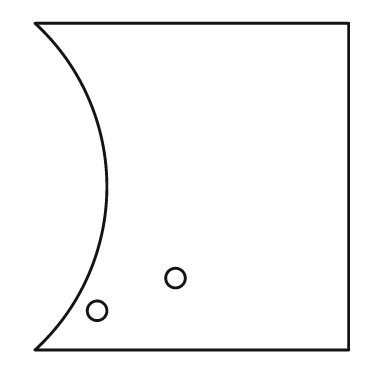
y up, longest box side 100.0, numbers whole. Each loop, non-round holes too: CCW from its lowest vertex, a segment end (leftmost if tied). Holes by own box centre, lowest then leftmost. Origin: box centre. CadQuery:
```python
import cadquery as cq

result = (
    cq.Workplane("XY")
    .moveTo(-48.0, -50.0)
    .lineTo(48.0, -50.0)
    .lineTo(48.0, 50.0)
    .lineTo(-48.0, 50.0)
    .threePointArc((-26.0, 0.0), (-48.0, -50.0))
    .close()
    .moveTo(-29.0, -38.0)
    .circle(3.0)
    .moveTo(-5.0, -28.0)
    .circle(3.0)
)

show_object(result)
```